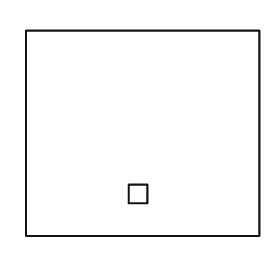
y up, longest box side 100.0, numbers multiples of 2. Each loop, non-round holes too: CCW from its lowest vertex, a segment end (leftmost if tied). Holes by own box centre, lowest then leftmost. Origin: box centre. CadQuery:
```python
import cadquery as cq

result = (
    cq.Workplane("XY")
    .moveTo(-50.0, -44.0)
    .lineTo(50.0, -44.0)
    .lineTo(50.0, 44.0)
    .lineTo(-50.0, 44.0)
    .close()
    .moveTo(-6.0, -30.0)
    .lineTo(2.0, -30.0)
    .lineTo(2.0, -22.0)
    .lineTo(-6.0, -22.0)
    .close()
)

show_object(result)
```